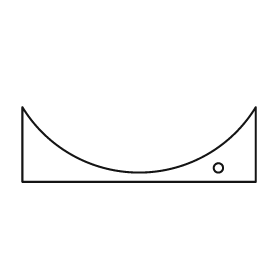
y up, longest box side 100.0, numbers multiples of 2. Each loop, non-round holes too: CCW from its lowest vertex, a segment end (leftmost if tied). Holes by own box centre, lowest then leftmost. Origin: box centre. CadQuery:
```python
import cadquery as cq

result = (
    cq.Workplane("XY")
    .moveTo(-50.0, -16.0)
    .lineTo(50.0, -16.0)
    .lineTo(50.0, 16.0)
    .threePointArc((0.0, -12.0), (-50.0, 16.0))
    .close()
    .moveTo(34.0, -10.0)
    .circle(2.0)
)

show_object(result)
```